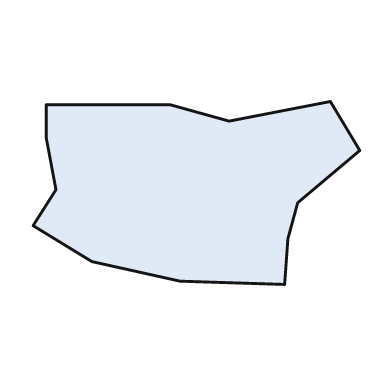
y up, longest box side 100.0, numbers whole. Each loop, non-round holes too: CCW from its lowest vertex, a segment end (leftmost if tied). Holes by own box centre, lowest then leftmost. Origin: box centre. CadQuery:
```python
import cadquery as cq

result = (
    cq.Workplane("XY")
    .moveTo(27.0, -28.0)
    .lineTo(28.0, -14.0)
    .lineTo(31.0, -3.0)
    .lineTo(50.0, 13.0)
    .lineTo(41.0, 28.0)
    .lineTo(10.0, 22.0)
    .lineTo(-8.0, 27.0)
    .lineTo(-46.0, 27.0)
    .lineTo(-46.0, 17.0)
    .lineTo(-43.0, 1.0)
    .lineTo(-50.0, -10.0)
    .lineTo(-32.0, -21.0)
    .lineTo(-5.0, -27.0)
    .close()
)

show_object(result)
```